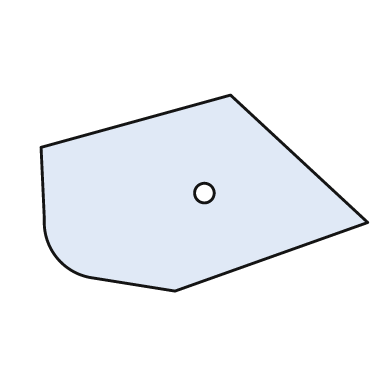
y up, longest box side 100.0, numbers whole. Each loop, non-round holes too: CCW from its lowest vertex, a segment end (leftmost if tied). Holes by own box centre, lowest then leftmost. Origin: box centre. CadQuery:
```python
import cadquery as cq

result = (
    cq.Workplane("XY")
    .moveTo(-9.0, -30.0)
    .lineTo(50.0, -9.0)
    .lineTo(8.0, 30.0)
    .lineTo(-50.0, 14.0)
    .lineTo(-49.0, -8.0)
    .threePointArc((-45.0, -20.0), (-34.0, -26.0))
    .close()
    .moveTo(0.0, 0.0)
    .circle(3.0)
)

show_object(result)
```